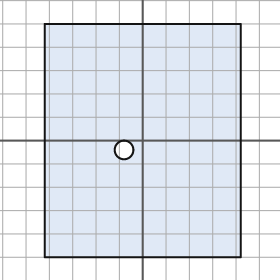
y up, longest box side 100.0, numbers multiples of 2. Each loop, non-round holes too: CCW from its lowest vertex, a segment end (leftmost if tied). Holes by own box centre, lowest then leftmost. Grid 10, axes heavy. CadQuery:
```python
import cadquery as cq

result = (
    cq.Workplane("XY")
    .moveTo(-42.0, -50.0)
    .lineTo(42.0, -50.0)
    .lineTo(42.0, 50.0)
    .lineTo(-42.0, 50.0)
    .close()
    .moveTo(-8.0, -4.0)
    .circle(4.0)
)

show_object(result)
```